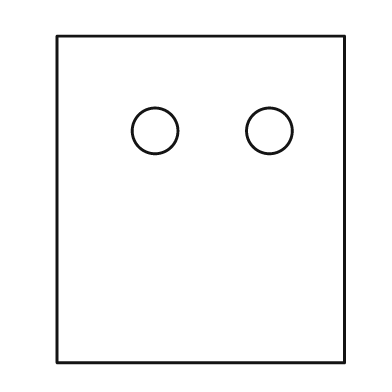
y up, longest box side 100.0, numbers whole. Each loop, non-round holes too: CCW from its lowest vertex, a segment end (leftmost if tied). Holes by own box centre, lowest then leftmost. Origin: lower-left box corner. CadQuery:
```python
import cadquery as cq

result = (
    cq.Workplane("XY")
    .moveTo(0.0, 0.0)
    .lineTo(88.0, 0.0)
    .lineTo(88.0, 100.0)
    .lineTo(0.0, 100.0)
    .close()
    .moveTo(30.0, 71.0)
    .circle(7.0)
    .moveTo(65.0, 71.0)
    .circle(7.0)
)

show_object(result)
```